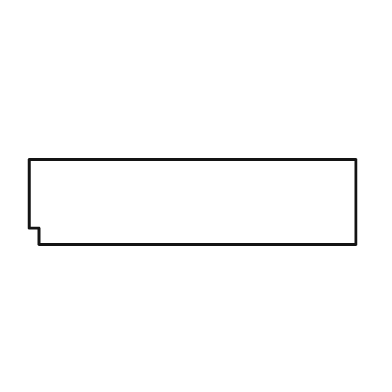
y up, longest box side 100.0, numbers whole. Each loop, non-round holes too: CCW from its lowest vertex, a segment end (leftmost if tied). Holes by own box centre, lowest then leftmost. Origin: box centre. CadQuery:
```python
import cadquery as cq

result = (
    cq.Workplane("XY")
    .moveTo(-47.0, -13.0)
    .lineTo(50.0, -13.0)
    .lineTo(50.0, 13.0)
    .lineTo(-50.0, 13.0)
    .lineTo(-50.0, -8.0)
    .lineTo(-47.0, -8.0)
    .close()
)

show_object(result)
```